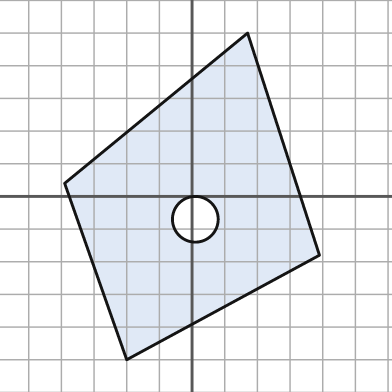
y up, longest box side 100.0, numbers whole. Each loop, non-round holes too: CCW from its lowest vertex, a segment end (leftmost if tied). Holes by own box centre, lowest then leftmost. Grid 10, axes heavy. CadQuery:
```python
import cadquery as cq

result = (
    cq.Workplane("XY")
    .moveTo(-20.0, -50.0)
    .lineTo(39.0, -18.0)
    .lineTo(17.0, 50.0)
    .lineTo(-39.0, 4.0)
    .close()
    .moveTo(1.0, -7.0)
    .circle(7.0)
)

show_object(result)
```